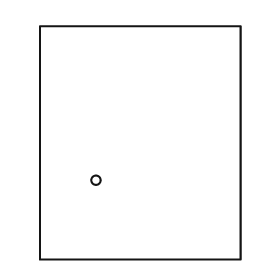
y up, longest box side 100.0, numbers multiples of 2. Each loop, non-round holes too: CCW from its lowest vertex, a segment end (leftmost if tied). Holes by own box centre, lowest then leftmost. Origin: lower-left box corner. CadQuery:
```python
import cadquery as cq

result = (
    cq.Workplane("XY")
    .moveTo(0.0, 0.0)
    .lineTo(86.0, 0.0)
    .lineTo(86.0, 100.0)
    .lineTo(0.0, 100.0)
    .close()
    .moveTo(24.0, 34.0)
    .circle(2.0)
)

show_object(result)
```